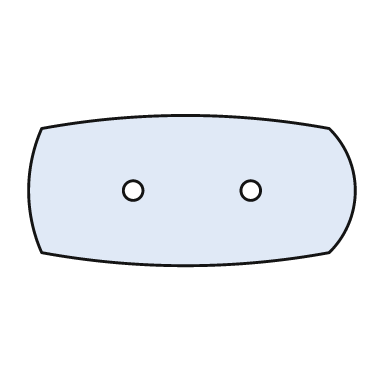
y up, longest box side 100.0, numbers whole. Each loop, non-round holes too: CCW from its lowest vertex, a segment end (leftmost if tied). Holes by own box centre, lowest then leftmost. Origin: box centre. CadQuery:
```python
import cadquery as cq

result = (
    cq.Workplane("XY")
    .moveTo(-46.0, -19.0)
    .threePointArc((-2.0, -23.0), (42.0, -19.0))
    .threePointArc((50.0, 0.0), (42.0, 19.0))
    .threePointArc((-2.0, 23.0), (-46.0, 19.0))
    .threePointArc((-50.0, 0.0), (-46.0, -19.0))
    .close()
    .moveTo(-18.0, 0.0)
    .circle(3.0)
    .moveTo(18.0, 0.0)
    .circle(3.0)
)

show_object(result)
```